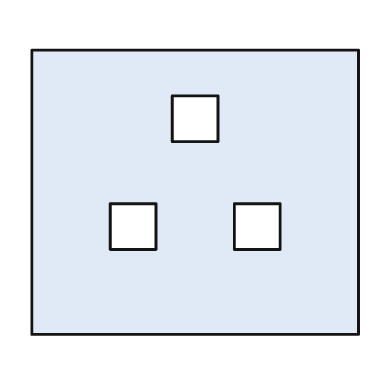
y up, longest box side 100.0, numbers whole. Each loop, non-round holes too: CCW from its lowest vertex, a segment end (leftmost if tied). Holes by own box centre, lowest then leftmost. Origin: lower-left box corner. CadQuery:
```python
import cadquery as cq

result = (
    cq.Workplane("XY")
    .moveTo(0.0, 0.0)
    .lineTo(100.0, 0.0)
    .lineTo(100.0, 87.0)
    .lineTo(0.0, 87.0)
    .close()
    .moveTo(24.0, 26.0)
    .lineTo(38.0, 26.0)
    .lineTo(38.0, 40.0)
    .lineTo(24.0, 40.0)
    .close()
    .moveTo(62.0, 26.0)
    .lineTo(76.0, 26.0)
    .lineTo(76.0, 40.0)
    .lineTo(62.0, 40.0)
    .close()
    .moveTo(43.0, 59.0)
    .lineTo(57.0, 59.0)
    .lineTo(57.0, 73.0)
    .lineTo(43.0, 73.0)
    .close()
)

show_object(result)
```